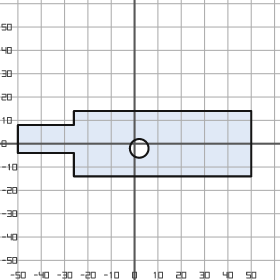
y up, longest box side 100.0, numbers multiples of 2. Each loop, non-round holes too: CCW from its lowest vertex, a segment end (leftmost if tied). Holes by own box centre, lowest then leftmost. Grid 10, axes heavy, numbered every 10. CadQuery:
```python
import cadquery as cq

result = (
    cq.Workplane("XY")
    .moveTo(-26.0, -14.0)
    .lineTo(50.0, -14.0)
    .lineTo(50.0, 14.0)
    .lineTo(-26.0, 14.0)
    .lineTo(-26.0, 8.0)
    .lineTo(-50.0, 8.0)
    .lineTo(-50.0, -4.0)
    .lineTo(-26.0, -4.0)
    .close()
    .moveTo(2.0, -2.0)
    .circle(4.0)
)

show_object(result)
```